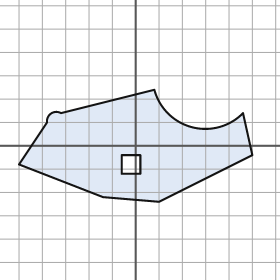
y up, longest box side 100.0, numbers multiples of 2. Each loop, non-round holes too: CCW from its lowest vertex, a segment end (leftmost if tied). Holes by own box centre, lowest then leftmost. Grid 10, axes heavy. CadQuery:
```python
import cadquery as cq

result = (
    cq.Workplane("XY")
    .moveTo(10.0, -24.0)
    .lineTo(50.0, -4.0)
    .lineTo(46.0, 14.0)
    .threePointArc((24.0, 8.0), (8.0, 24.0))
    .lineTo(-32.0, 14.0)
    .threePointArc((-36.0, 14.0), (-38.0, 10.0))
    .lineTo(-50.0, -8.0)
    .lineTo(-14.0, -22.0)
    .close()
    .moveTo(-6.0, -12.0)
    .lineTo(2.0, -12.0)
    .lineTo(2.0, -4.0)
    .lineTo(-6.0, -4.0)
    .close()
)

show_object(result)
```